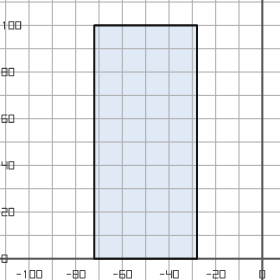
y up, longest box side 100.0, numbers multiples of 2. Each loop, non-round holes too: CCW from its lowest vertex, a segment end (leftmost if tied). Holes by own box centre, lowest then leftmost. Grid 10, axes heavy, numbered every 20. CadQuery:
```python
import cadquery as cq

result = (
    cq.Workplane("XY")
    .moveTo(-72.0, 0.0)
    .lineTo(-28.0, 0.0)
    .lineTo(-28.0, 100.0)
    .lineTo(-72.0, 100.0)
    .close()
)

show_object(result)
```